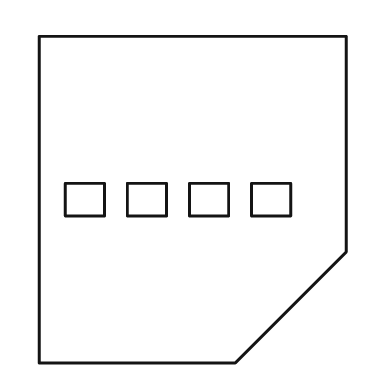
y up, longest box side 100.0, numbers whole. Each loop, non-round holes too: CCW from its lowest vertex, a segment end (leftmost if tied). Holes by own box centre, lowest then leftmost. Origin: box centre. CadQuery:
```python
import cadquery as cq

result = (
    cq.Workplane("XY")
    .moveTo(-47.0, -50.0)
    .lineTo(13.0, -50.0)
    .lineTo(47.0, -16.0)
    .lineTo(47.0, 50.0)
    .lineTo(-47.0, 50.0)
    .close()
    .moveTo(-39.0, -5.0)
    .lineTo(-27.0, -5.0)
    .lineTo(-27.0, 5.0)
    .lineTo(-39.0, 5.0)
    .close()
    .moveTo(-20.0, -5.0)
    .lineTo(-8.0, -5.0)
    .lineTo(-8.0, 5.0)
    .lineTo(-20.0, 5.0)
    .close()
    .moveTo(-1.0, -5.0)
    .lineTo(11.0, -5.0)
    .lineTo(11.0, 5.0)
    .lineTo(-1.0, 5.0)
    .close()
    .moveTo(18.0, -5.0)
    .lineTo(30.0, -5.0)
    .lineTo(30.0, 5.0)
    .lineTo(18.0, 5.0)
    .close()
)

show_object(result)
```